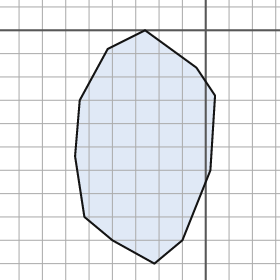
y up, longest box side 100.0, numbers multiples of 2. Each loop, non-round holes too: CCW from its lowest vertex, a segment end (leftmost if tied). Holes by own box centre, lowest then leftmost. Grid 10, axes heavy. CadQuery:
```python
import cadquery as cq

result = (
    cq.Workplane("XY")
    .moveTo(-22.0, -100.0)
    .lineTo(-10.0, -90.0)
    .lineTo(2.0, -60.0)
    .lineTo(4.0, -28.0)
    .lineTo(-4.0, -16.0)
    .lineTo(-26.0, 0.0)
    .lineTo(-42.0, -8.0)
    .lineTo(-54.0, -30.0)
    .lineTo(-56.0, -54.0)
    .lineTo(-52.0, -80.0)
    .lineTo(-40.0, -90.0)
    .close()
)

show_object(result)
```